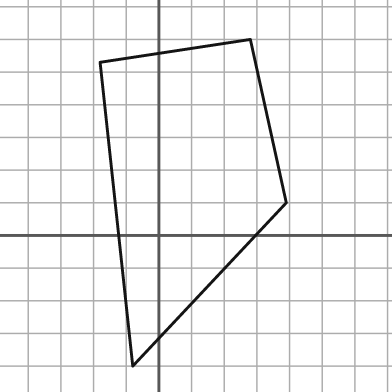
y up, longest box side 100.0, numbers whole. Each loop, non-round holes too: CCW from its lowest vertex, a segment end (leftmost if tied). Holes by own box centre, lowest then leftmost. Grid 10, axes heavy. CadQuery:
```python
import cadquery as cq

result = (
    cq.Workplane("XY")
    .moveTo(-8.0, -40.0)
    .lineTo(39.0, 10.0)
    .lineTo(28.0, 60.0)
    .lineTo(-18.0, 53.0)
    .close()
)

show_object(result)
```